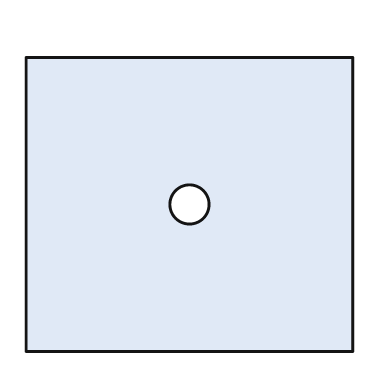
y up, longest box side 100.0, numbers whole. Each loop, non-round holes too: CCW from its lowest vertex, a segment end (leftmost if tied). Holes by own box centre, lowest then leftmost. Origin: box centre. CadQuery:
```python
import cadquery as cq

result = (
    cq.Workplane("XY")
    .moveTo(-50.0, -45.0)
    .lineTo(50.0, -45.0)
    .lineTo(50.0, 45.0)
    .lineTo(-50.0, 45.0)
    .close()
    .moveTo(0.0, 0.0)
    .circle(6.0)
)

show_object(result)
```